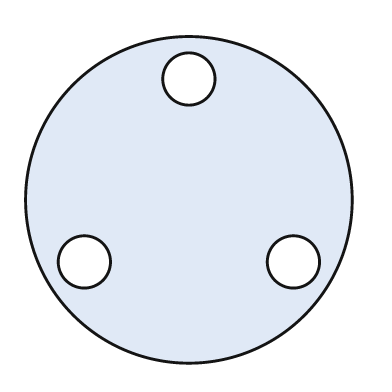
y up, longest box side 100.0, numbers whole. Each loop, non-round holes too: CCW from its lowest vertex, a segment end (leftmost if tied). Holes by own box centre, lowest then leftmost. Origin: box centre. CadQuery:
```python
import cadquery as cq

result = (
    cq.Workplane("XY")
    .moveTo(0.0, 0.0)
    .circle(50.0)
    .moveTo(-32.0, -19.0)
    .circle(8.0)
    .moveTo(32.0, -19.0)
    .circle(8.0)
    .moveTo(0.0, 37.0)
    .circle(8.0)
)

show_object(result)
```